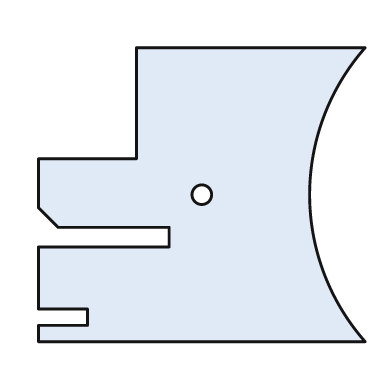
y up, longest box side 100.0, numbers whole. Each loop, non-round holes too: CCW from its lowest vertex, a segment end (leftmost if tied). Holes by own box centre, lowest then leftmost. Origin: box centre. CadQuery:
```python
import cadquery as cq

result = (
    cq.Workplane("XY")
    .moveTo(-50.0, -45.0)
    .lineTo(50.0, -45.0)
    .threePointArc((33.0, 0.0), (50.0, 45.0))
    .lineTo(-20.0, 45.0)
    .lineTo(-20.0, 11.0)
    .lineTo(-50.0, 11.0)
    .lineTo(-50.0, -4.0)
    .lineTo(-44.0, -10.0)
    .lineTo(-10.0, -10.0)
    .lineTo(-10.0, -16.0)
    .lineTo(-50.0, -16.0)
    .lineTo(-50.0, -35.0)
    .lineTo(-35.0, -35.0)
    .lineTo(-35.0, -40.0)
    .lineTo(-50.0, -40.0)
    .close()
    .moveTo(0.0, 0.0)
    .circle(3.0)
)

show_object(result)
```